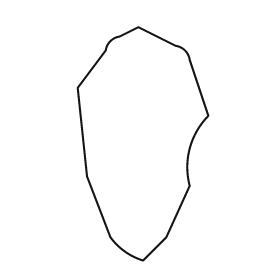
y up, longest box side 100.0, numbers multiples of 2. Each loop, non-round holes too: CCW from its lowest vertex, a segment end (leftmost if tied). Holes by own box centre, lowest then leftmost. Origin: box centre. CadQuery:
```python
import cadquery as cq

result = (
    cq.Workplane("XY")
    .moveTo(0.0, -50.0)
    .lineTo(10.0, -40.0)
    .lineTo(20.0, -18.0)
    .threePointArc((20.0, -2.0), (28.0, 12.0))
    .lineTo(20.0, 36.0)
    .threePointArc((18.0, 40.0), (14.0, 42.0))
    .lineTo(-2.0, 50.0)
    .lineTo(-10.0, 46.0)
    .threePointArc((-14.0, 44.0), (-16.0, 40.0))
    .lineTo(-28.0, 24.0)
    .lineTo(-24.0, -14.0)
    .lineTo(-14.0, -40.0)
    .threePointArc((-8.0, -46.0), (0.0, -50.0))
    .close()
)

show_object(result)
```